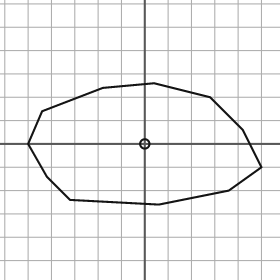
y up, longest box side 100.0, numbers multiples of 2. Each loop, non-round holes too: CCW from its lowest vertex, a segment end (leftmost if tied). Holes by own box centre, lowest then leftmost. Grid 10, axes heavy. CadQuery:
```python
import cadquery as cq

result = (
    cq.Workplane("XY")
    .moveTo(6.0, -26.0)
    .lineTo(36.0, -20.0)
    .lineTo(50.0, -10.0)
    .lineTo(42.0, 6.0)
    .lineTo(28.0, 20.0)
    .lineTo(4.0, 26.0)
    .lineTo(-18.0, 24.0)
    .lineTo(-44.0, 14.0)
    .lineTo(-50.0, 0.0)
    .lineTo(-42.0, -14.0)
    .lineTo(-32.0, -24.0)
    .close()
    .moveTo(0.0, 0.0)
    .circle(2.0)
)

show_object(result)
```